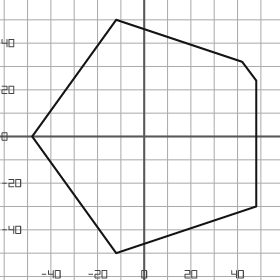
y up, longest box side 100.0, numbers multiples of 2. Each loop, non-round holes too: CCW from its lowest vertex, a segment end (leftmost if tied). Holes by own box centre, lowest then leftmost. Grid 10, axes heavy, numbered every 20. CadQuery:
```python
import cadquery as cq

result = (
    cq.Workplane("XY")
    .moveTo(-12.0, -50.0)
    .lineTo(48.0, -30.0)
    .lineTo(48.0, 24.0)
    .lineTo(42.0, 32.0)
    .lineTo(-12.0, 50.0)
    .lineTo(-48.0, 0.0)
    .close()
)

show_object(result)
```